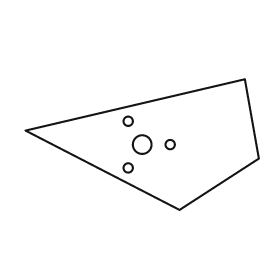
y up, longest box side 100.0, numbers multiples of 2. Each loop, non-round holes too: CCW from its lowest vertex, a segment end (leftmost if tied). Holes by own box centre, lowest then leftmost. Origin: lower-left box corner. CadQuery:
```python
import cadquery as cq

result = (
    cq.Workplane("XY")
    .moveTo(66.0, 0.0)
    .lineTo(100.0, 22.0)
    .lineTo(94.0, 56.0)
    .lineTo(0.0, 34.0)
    .close()
    .moveTo(44.0, 18.0)
    .circle(2.0)
    .moveTo(50.0, 28.0)
    .circle(4.0)
    .moveTo(62.0, 28.0)
    .circle(2.0)
    .moveTo(44.0, 38.0)
    .circle(2.0)
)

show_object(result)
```